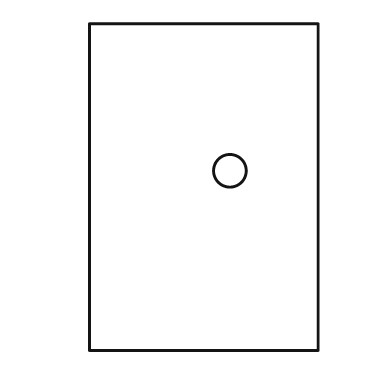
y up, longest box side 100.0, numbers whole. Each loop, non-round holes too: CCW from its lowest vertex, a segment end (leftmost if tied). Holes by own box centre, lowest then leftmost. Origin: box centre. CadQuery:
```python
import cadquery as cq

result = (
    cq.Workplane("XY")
    .moveTo(-35.0, -50.0)
    .lineTo(35.0, -50.0)
    .lineTo(35.0, 50.0)
    .lineTo(-35.0, 50.0)
    .close()
    .moveTo(8.0, 5.0)
    .circle(5.0)
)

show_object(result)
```